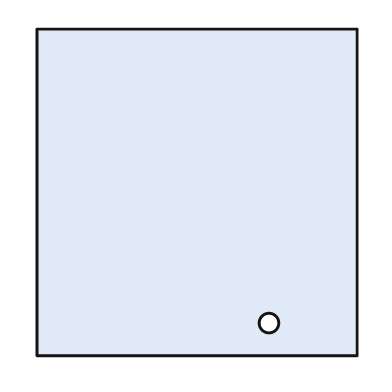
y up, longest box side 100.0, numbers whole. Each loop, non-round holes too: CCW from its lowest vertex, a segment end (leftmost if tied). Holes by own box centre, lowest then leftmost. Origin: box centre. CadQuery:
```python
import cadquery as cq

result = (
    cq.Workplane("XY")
    .moveTo(-49.0, -50.0)
    .lineTo(49.0, -50.0)
    .lineTo(49.0, 50.0)
    .lineTo(-49.0, 50.0)
    .close()
    .moveTo(22.0, -40.0)
    .circle(3.0)
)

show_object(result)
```